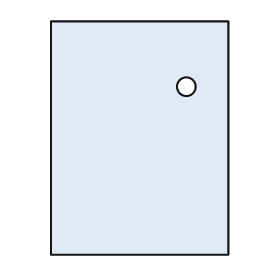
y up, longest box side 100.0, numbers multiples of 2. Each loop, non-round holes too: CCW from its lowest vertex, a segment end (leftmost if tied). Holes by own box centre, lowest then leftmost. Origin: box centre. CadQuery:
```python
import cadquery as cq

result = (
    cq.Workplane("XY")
    .moveTo(-38.0, -50.0)
    .lineTo(38.0, -50.0)
    .lineTo(38.0, 50.0)
    .lineTo(-38.0, 50.0)
    .close()
    .moveTo(20.0, 22.0)
    .circle(4.0)
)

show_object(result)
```